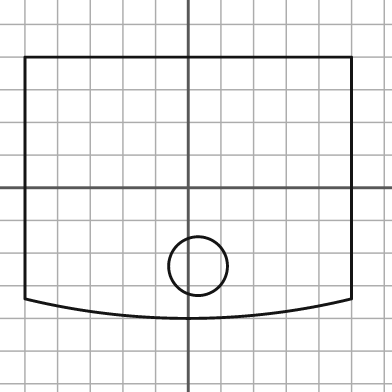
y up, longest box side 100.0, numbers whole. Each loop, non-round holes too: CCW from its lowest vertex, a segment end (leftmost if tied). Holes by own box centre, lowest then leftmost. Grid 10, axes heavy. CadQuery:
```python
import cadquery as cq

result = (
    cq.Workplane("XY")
    .moveTo(-50.0, -34.0)
    .threePointArc((0.0, -40.0), (50.0, -34.0))
    .lineTo(50.0, 40.0)
    .lineTo(-50.0, 40.0)
    .close()
    .moveTo(3.0, -24.0)
    .circle(9.0)
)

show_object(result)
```